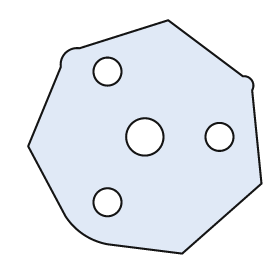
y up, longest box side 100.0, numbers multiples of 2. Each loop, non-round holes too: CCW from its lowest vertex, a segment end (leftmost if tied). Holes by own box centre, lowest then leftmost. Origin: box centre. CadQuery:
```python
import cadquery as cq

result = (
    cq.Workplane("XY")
    .moveTo(16.0, -50.0)
    .lineTo(50.0, -20.0)
    .lineTo(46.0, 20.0)
    .threePointArc((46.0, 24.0), (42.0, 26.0))
    .lineTo(10.0, 50.0)
    .lineTo(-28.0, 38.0)
    .threePointArc((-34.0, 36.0), (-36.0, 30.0))
    .lineTo(-50.0, -4.0)
    .lineTo(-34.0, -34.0)
    .threePointArc((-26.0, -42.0), (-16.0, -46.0))
    .close()
    .moveTo(-16.0, -28.0)
    .circle(6.0)
    .moveTo(0.0, 0.0)
    .circle(8.0)
    .moveTo(32.0, 0.0)
    .circle(6.0)
    .moveTo(-16.0, 28.0)
    .circle(6.0)
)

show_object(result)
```